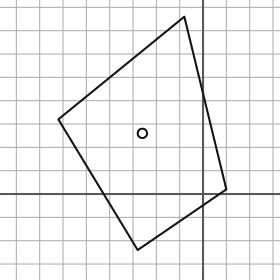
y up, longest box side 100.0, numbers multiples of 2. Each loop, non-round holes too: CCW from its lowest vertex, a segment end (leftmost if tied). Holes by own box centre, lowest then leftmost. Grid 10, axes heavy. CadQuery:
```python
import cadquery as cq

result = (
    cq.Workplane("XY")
    .moveTo(-28.0, -24.0)
    .lineTo(10.0, 2.0)
    .lineTo(-8.0, 76.0)
    .lineTo(-62.0, 32.0)
    .close()
    .moveTo(-26.0, 26.0)
    .circle(2.0)
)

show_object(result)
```